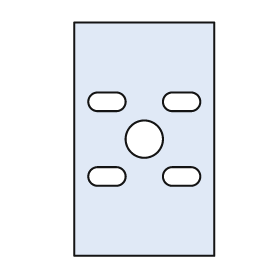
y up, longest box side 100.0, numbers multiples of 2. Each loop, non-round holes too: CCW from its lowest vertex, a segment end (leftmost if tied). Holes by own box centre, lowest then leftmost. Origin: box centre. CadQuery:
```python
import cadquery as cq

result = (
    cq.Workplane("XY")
    .moveTo(-30.0, -50.0)
    .lineTo(30.0, -50.0)
    .lineTo(30.0, 50.0)
    .lineTo(-30.0, 50.0)
    .close()
    .moveTo(-20.0, -20.0)
    .lineTo(-12.0, -20.0)
    .threePointArc((-8.0, -16.0), (-12.0, -12.0))
    .lineTo(-20.0, -12.0)
    .threePointArc((-24.0, -16.0), (-20.0, -20.0))
    .close()
    .moveTo(12.0, -20.0)
    .lineTo(20.0, -20.0)
    .threePointArc((24.0, -16.0), (20.0, -12.0))
    .lineTo(12.0, -12.0)
    .threePointArc((8.0, -16.0), (12.0, -20.0))
    .close()
    .moveTo(0.0, 0.0)
    .circle(8.0)
    .moveTo(-20.0, 12.0)
    .lineTo(-12.0, 12.0)
    .threePointArc((-8.0, 16.0), (-12.0, 20.0))
    .lineTo(-20.0, 20.0)
    .threePointArc((-24.0, 16.0), (-20.0, 12.0))
    .close()
    .moveTo(12.0, 12.0)
    .lineTo(20.0, 12.0)
    .threePointArc((24.0, 16.0), (20.0, 20.0))
    .lineTo(12.0, 20.0)
    .threePointArc((8.0, 16.0), (12.0, 12.0))
    .close()
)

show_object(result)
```